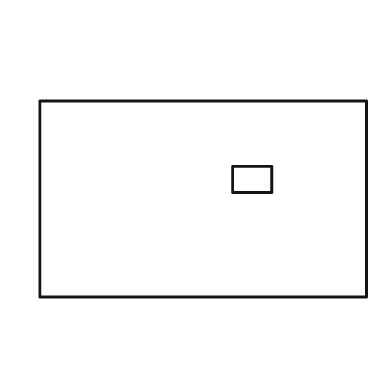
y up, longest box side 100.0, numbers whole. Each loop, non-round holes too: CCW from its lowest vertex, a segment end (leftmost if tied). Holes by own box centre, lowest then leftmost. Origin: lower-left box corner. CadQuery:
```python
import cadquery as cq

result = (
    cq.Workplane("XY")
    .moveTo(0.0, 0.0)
    .lineTo(100.0, 0.0)
    .lineTo(100.0, 60.0)
    .lineTo(0.0, 60.0)
    .close()
    .moveTo(59.0, 32.0)
    .lineTo(71.0, 32.0)
    .lineTo(71.0, 40.0)
    .lineTo(59.0, 40.0)
    .close()
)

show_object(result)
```